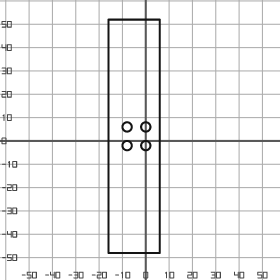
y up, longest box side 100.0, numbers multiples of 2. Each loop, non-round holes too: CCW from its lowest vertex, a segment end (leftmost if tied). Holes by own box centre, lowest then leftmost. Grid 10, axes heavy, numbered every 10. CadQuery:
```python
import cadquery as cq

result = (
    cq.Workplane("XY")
    .moveTo(-16.0, -48.0)
    .lineTo(6.0, -48.0)
    .lineTo(6.0, 52.0)
    .lineTo(-16.0, 52.0)
    .close()
    .moveTo(-8.0, -2.0)
    .circle(2.0)
    .moveTo(0.0, -2.0)
    .circle(2.0)
    .moveTo(-8.0, 6.0)
    .circle(2.0)
    .moveTo(0.0, 6.0)
    .circle(2.0)
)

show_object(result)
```